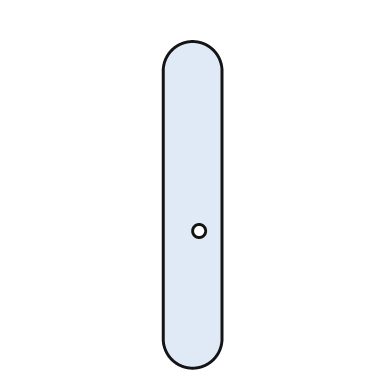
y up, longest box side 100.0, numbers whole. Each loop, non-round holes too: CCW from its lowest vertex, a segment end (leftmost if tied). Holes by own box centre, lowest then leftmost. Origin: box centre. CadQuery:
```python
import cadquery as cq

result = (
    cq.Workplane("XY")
    .moveTo(-9.0, -41.0)
    .threePointArc((0.0, -50.0), (9.0, -41.0))
    .lineTo(9.0, 41.0)
    .threePointArc((0.0, 50.0), (-9.0, 41.0))
    .close()
    .moveTo(2.0, -8.0)
    .circle(2.0)
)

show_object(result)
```